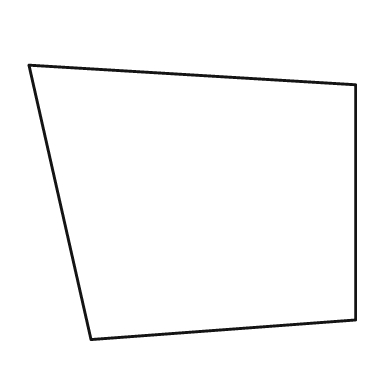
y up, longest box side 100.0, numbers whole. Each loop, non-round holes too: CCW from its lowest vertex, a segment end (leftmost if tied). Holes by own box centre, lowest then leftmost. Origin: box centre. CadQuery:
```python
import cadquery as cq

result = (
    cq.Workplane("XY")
    .moveTo(-31.0, -42.0)
    .lineTo(50.0, -36.0)
    .lineTo(50.0, 36.0)
    .lineTo(-50.0, 42.0)
    .close()
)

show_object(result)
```